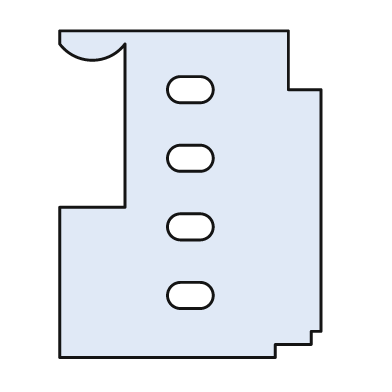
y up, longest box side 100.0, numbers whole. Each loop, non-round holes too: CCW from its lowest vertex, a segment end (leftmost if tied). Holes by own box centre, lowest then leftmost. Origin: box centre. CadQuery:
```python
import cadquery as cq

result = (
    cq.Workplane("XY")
    .moveTo(-40.0, -50.0)
    .lineTo(26.0, -50.0)
    .lineTo(26.0, -46.0)
    .lineTo(37.0, -46.0)
    .lineTo(37.0, -42.0)
    .lineTo(40.0, -42.0)
    .lineTo(40.0, 32.0)
    .lineTo(30.0, 32.0)
    .lineTo(30.0, 50.0)
    .lineTo(-40.0, 50.0)
    .lineTo(-40.0, 46.0)
    .threePointArc((-30.0, 41.0), (-20.0, 46.0))
    .lineTo(-20.0, -4.0)
    .lineTo(-40.0, -4.0)
    .close()
    .moveTo(-3.0, -35.0)
    .lineTo(3.0, -35.0)
    .threePointArc((7.0, -31.0), (3.0, -27.0))
    .lineTo(-3.0, -27.0)
    .threePointArc((-7.0, -31.0), (-3.0, -35.0))
    .close()
    .moveTo(-3.0, -14.0)
    .lineTo(3.0, -14.0)
    .threePointArc((7.0, -10.0), (3.0, -6.0))
    .lineTo(-3.0, -6.0)
    .threePointArc((-7.0, -10.0), (-3.0, -14.0))
    .close()
    .moveTo(-3.0, 7.0)
    .lineTo(3.0, 7.0)
    .threePointArc((7.0, 11.0), (3.0, 15.0))
    .lineTo(-3.0, 15.0)
    .threePointArc((-7.0, 11.0), (-3.0, 7.0))
    .close()
    .moveTo(-3.0, 28.0)
    .lineTo(3.0, 28.0)
    .threePointArc((7.0, 32.0), (3.0, 36.0))
    .lineTo(-3.0, 36.0)
    .threePointArc((-7.0, 32.0), (-3.0, 28.0))
    .close()
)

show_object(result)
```